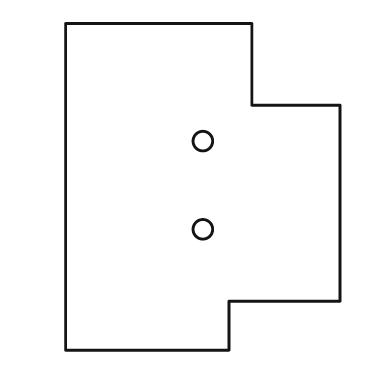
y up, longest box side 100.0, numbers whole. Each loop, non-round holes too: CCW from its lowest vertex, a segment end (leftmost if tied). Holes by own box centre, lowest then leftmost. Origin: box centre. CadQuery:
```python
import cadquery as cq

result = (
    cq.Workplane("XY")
    .moveTo(-42.0, -50.0)
    .lineTo(8.0, -50.0)
    .lineTo(8.0, -35.0)
    .lineTo(42.0, -35.0)
    .lineTo(42.0, 25.0)
    .lineTo(15.0, 25.0)
    .lineTo(15.0, 50.0)
    .lineTo(-42.0, 50.0)
    .close()
    .moveTo(0.0, -13.0)
    .circle(3.0)
    .moveTo(0.0, 14.0)
    .circle(3.0)
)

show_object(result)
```